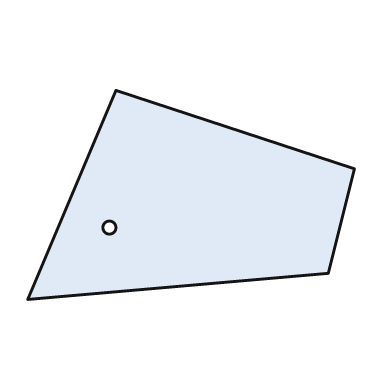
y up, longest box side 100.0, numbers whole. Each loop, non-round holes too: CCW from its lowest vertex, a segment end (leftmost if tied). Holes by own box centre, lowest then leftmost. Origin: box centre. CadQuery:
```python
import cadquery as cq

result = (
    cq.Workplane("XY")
    .moveTo(-50.0, -32.0)
    .lineTo(42.0, -24.0)
    .lineTo(50.0, 8.0)
    .lineTo(-23.0, 32.0)
    .close()
    .moveTo(-25.0, -10.0)
    .circle(2.0)
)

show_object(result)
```